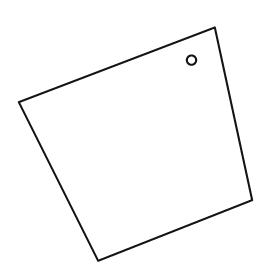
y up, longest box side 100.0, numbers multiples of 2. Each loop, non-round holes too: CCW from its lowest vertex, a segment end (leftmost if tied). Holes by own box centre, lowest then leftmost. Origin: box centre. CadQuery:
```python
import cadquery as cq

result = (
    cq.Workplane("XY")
    .moveTo(-16.0, -50.0)
    .lineTo(50.0, -24.0)
    .lineTo(34.0, 50.0)
    .lineTo(-50.0, 18.0)
    .close()
    .moveTo(24.0, 36.0)
    .circle(2.0)
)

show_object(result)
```